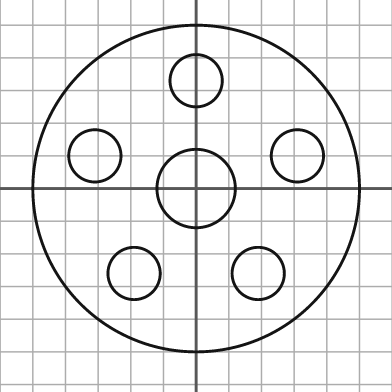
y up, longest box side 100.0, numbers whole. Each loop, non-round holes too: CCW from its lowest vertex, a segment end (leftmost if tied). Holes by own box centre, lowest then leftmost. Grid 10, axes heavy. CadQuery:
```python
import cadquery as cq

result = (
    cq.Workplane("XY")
    .moveTo(0.0, 0.0)
    .circle(50.0)
    .moveTo(-19.0, -26.0)
    .circle(8.0)
    .moveTo(19.0, -26.0)
    .circle(8.0)
    .moveTo(0.0, 0.0)
    .circle(12.0)
    .moveTo(-31.0, 10.0)
    .circle(8.0)
    .moveTo(31.0, 10.0)
    .circle(8.0)
    .moveTo(0.0, 33.0)
    .circle(8.0)
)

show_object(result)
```